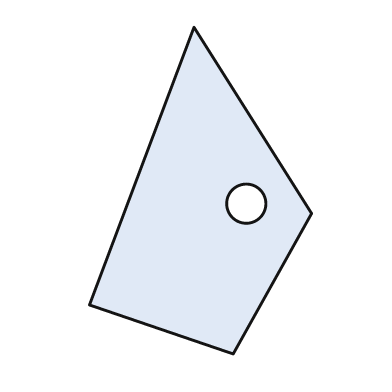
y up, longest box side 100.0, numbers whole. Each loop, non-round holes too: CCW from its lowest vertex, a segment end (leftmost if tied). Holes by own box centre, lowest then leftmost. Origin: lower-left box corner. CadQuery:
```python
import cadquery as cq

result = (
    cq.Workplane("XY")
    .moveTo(44.0, 0.0)
    .lineTo(68.0, 43.0)
    .lineTo(32.0, 100.0)
    .lineTo(0.0, 15.0)
    .close()
    .moveTo(48.0, 46.0)
    .circle(6.0)
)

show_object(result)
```